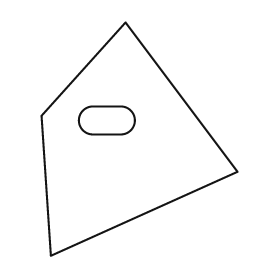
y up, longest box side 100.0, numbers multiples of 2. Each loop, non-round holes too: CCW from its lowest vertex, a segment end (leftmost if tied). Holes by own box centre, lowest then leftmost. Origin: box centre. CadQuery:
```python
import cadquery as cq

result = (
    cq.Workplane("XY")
    .moveTo(-38.0, -50.0)
    .lineTo(42.0, -14.0)
    .lineTo(-6.0, 50.0)
    .lineTo(-42.0, 10.0)
    .close()
    .moveTo(-20.0, 2.0)
    .lineTo(-8.0, 2.0)
    .threePointArc((-2.0, 8.0), (-8.0, 14.0))
    .lineTo(-20.0, 14.0)
    .threePointArc((-26.0, 8.0), (-20.0, 2.0))
    .close()
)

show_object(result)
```